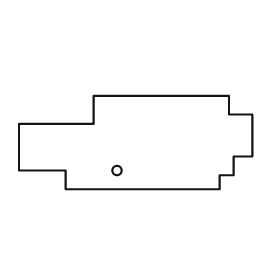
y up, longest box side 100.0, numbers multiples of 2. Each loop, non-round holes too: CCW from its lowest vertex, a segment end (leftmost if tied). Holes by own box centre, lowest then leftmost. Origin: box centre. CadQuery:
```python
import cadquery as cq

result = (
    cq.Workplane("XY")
    .moveTo(-30.0, -20.0)
    .lineTo(36.0, -20.0)
    .lineTo(36.0, -14.0)
    .lineTo(42.0, -14.0)
    .lineTo(42.0, -6.0)
    .lineTo(50.0, -6.0)
    .lineTo(50.0, 12.0)
    .lineTo(40.0, 12.0)
    .lineTo(40.0, 20.0)
    .lineTo(-18.0, 20.0)
    .lineTo(-18.0, 8.0)
    .lineTo(-50.0, 8.0)
    .lineTo(-50.0, -12.0)
    .lineTo(-30.0, -12.0)
    .close()
    .moveTo(-8.0, -12.0)
    .circle(2.0)
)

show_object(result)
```